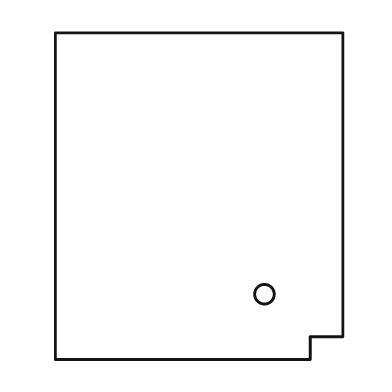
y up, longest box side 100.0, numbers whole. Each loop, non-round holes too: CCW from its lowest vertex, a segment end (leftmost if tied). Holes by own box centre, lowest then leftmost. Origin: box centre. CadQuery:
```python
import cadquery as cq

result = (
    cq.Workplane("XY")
    .moveTo(-44.0, -50.0)
    .lineTo(34.0, -50.0)
    .lineTo(34.0, -43.0)
    .lineTo(44.0, -43.0)
    .lineTo(44.0, 50.0)
    .lineTo(-44.0, 50.0)
    .close()
    .moveTo(20.0, -30.0)
    .circle(3.0)
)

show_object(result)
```